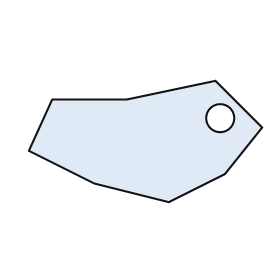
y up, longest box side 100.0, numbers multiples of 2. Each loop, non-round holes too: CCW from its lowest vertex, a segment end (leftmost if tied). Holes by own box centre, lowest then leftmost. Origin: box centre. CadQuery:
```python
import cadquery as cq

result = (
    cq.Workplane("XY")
    .moveTo(10.0, -26.0)
    .lineTo(34.0, -14.0)
    .lineTo(50.0, 6.0)
    .lineTo(30.0, 26.0)
    .lineTo(-8.0, 18.0)
    .lineTo(-40.0, 18.0)
    .lineTo(-50.0, -4.0)
    .lineTo(-22.0, -18.0)
    .close()
    .moveTo(32.0, 10.0)
    .circle(6.0)
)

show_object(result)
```